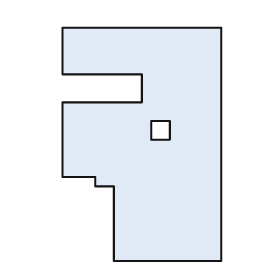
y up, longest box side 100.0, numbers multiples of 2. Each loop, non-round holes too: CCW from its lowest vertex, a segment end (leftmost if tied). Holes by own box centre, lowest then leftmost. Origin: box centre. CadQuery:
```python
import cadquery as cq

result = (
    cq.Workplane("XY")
    .moveTo(-12.0, -50.0)
    .lineTo(34.0, -50.0)
    .lineTo(34.0, 50.0)
    .lineTo(-34.0, 50.0)
    .lineTo(-34.0, 30.0)
    .lineTo(0.0, 30.0)
    .lineTo(0.0, 18.0)
    .lineTo(-34.0, 18.0)
    .lineTo(-34.0, -14.0)
    .lineTo(-20.0, -14.0)
    .lineTo(-20.0, -18.0)
    .lineTo(-12.0, -18.0)
    .close()
    .moveTo(4.0, 2.0)
    .lineTo(12.0, 2.0)
    .lineTo(12.0, 10.0)
    .lineTo(4.0, 10.0)
    .close()
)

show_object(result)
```